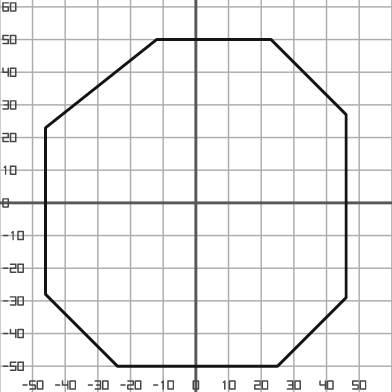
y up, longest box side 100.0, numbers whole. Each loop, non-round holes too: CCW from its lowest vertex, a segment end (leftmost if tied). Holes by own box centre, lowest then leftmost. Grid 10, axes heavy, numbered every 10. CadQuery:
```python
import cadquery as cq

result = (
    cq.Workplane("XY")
    .moveTo(-24.0, -50.0)
    .lineTo(25.0, -50.0)
    .lineTo(46.0, -29.0)
    .lineTo(46.0, 27.0)
    .lineTo(23.0, 50.0)
    .lineTo(-12.0, 50.0)
    .lineTo(-46.0, 23.0)
    .lineTo(-46.0, -28.0)
    .close()
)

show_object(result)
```